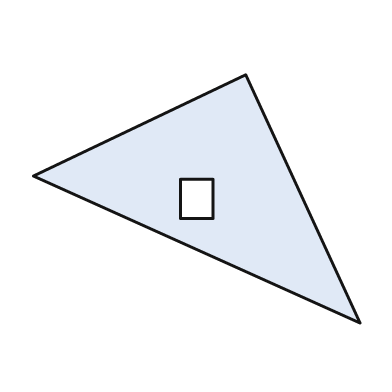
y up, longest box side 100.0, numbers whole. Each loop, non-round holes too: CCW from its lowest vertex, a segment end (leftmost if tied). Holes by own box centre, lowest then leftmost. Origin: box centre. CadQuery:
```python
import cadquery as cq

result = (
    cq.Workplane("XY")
    .moveTo(50.0, -38.0)
    .lineTo(15.0, 38.0)
    .lineTo(-50.0, 7.0)
    .close()
    .moveTo(-5.0, -6.0)
    .lineTo(5.0, -6.0)
    .lineTo(5.0, 6.0)
    .lineTo(-5.0, 6.0)
    .close()
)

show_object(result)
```